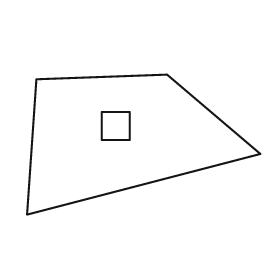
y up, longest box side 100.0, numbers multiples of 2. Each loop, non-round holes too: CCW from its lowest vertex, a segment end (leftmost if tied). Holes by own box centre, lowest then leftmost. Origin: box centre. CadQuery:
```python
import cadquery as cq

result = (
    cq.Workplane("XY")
    .moveTo(-50.0, -30.0)
    .lineTo(50.0, -4.0)
    .lineTo(10.0, 30.0)
    .lineTo(-46.0, 28.0)
    .close()
    .moveTo(-18.0, 2.0)
    .lineTo(-6.0, 2.0)
    .lineTo(-6.0, 14.0)
    .lineTo(-18.0, 14.0)
    .close()
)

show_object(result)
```